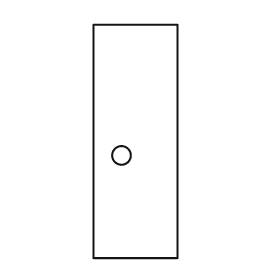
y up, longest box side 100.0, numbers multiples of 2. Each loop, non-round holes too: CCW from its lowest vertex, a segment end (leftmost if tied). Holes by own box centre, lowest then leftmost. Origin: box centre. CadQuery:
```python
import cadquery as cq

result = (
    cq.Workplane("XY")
    .moveTo(-18.0, -50.0)
    .lineTo(18.0, -50.0)
    .lineTo(18.0, 50.0)
    .lineTo(-18.0, 50.0)
    .close()
    .moveTo(-6.0, -6.0)
    .circle(4.0)
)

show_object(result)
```